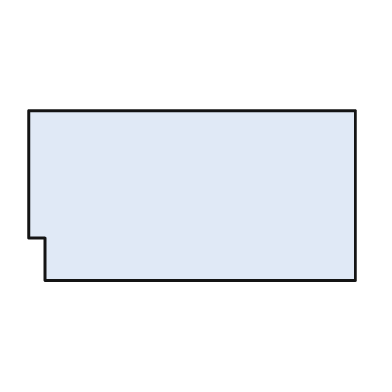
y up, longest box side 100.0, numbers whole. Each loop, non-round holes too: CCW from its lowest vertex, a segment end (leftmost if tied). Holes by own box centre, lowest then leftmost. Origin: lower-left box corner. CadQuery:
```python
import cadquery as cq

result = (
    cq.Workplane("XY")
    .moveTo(5.0, 0.0)
    .lineTo(100.0, 0.0)
    .lineTo(100.0, 52.0)
    .lineTo(0.0, 52.0)
    .lineTo(0.0, 13.0)
    .lineTo(5.0, 13.0)
    .close()
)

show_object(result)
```